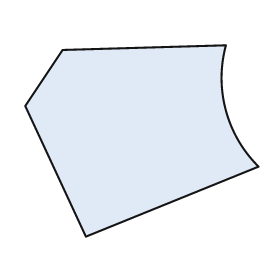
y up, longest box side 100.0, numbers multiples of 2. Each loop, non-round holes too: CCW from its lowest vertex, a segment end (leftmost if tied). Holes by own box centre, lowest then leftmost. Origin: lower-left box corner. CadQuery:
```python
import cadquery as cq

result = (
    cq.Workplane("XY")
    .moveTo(26.0, 0.0)
    .lineTo(100.0, 30.0)
    .threePointArc((86.0, 54.0), (86.0, 82.0))
    .lineTo(16.0, 80.0)
    .lineTo(0.0, 56.0)
    .close()
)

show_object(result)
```